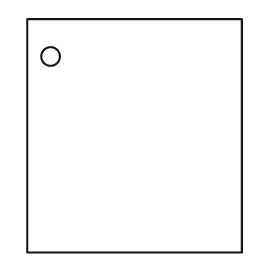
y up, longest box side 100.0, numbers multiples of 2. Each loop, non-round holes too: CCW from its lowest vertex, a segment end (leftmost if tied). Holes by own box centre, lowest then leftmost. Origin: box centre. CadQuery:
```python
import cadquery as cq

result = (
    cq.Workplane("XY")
    .moveTo(-46.0, -50.0)
    .lineTo(46.0, -50.0)
    .lineTo(46.0, 50.0)
    .lineTo(-46.0, 50.0)
    .close()
    .moveTo(-36.0, 34.0)
    .circle(4.0)
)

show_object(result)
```